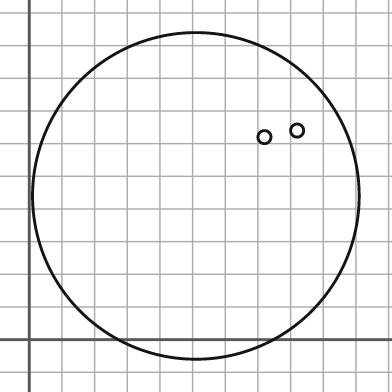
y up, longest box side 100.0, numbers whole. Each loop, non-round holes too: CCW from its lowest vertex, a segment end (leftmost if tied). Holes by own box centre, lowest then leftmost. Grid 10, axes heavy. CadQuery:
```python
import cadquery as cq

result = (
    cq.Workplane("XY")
    .moveTo(51.0, 44.0)
    .circle(50.0)
    .moveTo(72.0, 62.0)
    .circle(2.0)
    .moveTo(82.0, 64.0)
    .circle(2.0)
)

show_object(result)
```